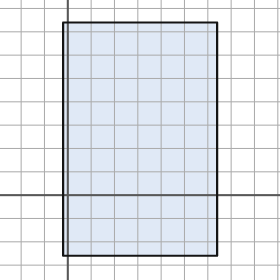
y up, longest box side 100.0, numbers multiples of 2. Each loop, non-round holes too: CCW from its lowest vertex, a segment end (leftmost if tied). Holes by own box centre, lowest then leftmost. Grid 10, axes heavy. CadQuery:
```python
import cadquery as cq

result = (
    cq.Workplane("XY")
    .moveTo(-2.0, -26.0)
    .lineTo(64.0, -26.0)
    .lineTo(64.0, 74.0)
    .lineTo(-2.0, 74.0)
    .close()
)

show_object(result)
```